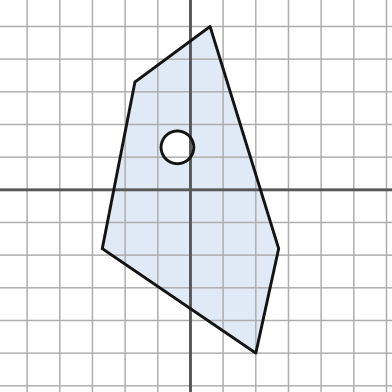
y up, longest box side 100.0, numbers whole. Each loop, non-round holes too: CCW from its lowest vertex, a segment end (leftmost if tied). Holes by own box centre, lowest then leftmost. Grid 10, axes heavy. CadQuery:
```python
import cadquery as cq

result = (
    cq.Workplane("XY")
    .moveTo(20.0, -50.0)
    .lineTo(27.0, -18.0)
    .lineTo(6.0, 50.0)
    .lineTo(-17.0, 33.0)
    .lineTo(-27.0, -18.0)
    .close()
    .moveTo(-4.0, 13.0)
    .circle(5.0)
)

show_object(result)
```